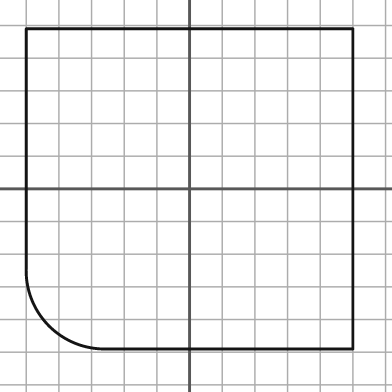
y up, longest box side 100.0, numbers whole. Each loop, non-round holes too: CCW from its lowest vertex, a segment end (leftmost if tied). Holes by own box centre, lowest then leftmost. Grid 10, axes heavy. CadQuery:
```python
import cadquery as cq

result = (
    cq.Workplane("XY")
    .moveTo(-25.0, -49.0)
    .lineTo(50.0, -49.0)
    .lineTo(50.0, 49.0)
    .lineTo(-50.0, 49.0)
    .lineTo(-50.0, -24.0)
    .threePointArc((-43.0, -42.0), (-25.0, -49.0))
    .close()
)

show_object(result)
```